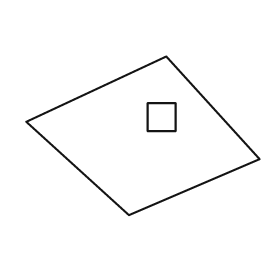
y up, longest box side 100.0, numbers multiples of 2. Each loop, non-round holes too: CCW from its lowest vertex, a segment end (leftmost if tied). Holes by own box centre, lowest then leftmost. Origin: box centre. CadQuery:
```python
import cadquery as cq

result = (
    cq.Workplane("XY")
    .moveTo(-6.0, -34.0)
    .lineTo(50.0, -10.0)
    .lineTo(10.0, 34.0)
    .lineTo(-50.0, 6.0)
    .close()
    .moveTo(2.0, 2.0)
    .lineTo(14.0, 2.0)
    .lineTo(14.0, 14.0)
    .lineTo(2.0, 14.0)
    .close()
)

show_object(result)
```